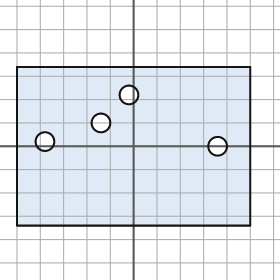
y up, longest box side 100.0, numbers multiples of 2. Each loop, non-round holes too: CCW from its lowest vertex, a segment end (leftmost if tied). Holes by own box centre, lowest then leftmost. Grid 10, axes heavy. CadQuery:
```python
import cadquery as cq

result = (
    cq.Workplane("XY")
    .moveTo(-50.0, -34.0)
    .lineTo(50.0, -34.0)
    .lineTo(50.0, 34.0)
    .lineTo(-50.0, 34.0)
    .close()
    .moveTo(36.0, 0.0)
    .circle(4.0)
    .moveTo(-38.0, 2.0)
    .circle(4.0)
    .moveTo(-14.0, 10.0)
    .circle(4.0)
    .moveTo(-2.0, 22.0)
    .circle(4.0)
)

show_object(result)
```